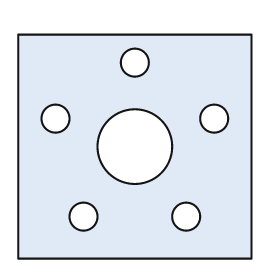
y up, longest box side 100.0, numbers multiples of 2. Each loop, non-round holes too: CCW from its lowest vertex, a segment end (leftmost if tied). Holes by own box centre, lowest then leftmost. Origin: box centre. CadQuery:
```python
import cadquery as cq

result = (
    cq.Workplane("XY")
    .moveTo(-50.0, -48.0)
    .lineTo(50.0, -48.0)
    .lineTo(50.0, 48.0)
    .lineTo(-50.0, 48.0)
    .close()
    .moveTo(-22.0, -30.0)
    .circle(6.0)
    .moveTo(22.0, -30.0)
    .circle(6.0)
    .moveTo(0.0, 0.0)
    .circle(16.0)
    .moveTo(-34.0, 12.0)
    .circle(6.0)
    .moveTo(34.0, 12.0)
    .circle(6.0)
    .moveTo(0.0, 36.0)
    .circle(6.0)
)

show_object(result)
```